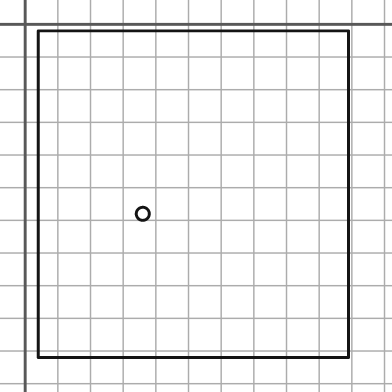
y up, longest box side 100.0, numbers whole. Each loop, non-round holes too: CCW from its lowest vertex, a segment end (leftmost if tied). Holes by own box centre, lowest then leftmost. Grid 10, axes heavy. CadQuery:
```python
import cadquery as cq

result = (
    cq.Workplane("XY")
    .moveTo(4.0, -102.0)
    .lineTo(99.0, -102.0)
    .lineTo(99.0, -2.0)
    .lineTo(4.0, -2.0)
    .close()
    .moveTo(36.0, -58.0)
    .circle(2.0)
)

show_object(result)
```